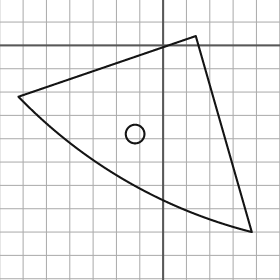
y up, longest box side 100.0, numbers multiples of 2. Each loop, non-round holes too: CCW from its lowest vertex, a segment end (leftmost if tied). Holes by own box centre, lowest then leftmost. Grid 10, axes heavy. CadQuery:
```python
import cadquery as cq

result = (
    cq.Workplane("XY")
    .moveTo(38.0, -80.0)
    .lineTo(14.0, 4.0)
    .lineTo(-62.0, -22.0)
    .threePointArc((-16.0, -58.0), (38.0, -80.0))
    .close()
    .moveTo(-12.0, -38.0)
    .circle(4.0)
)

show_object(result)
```